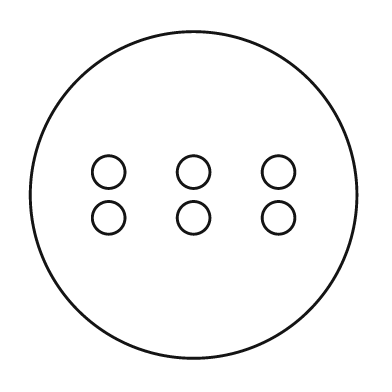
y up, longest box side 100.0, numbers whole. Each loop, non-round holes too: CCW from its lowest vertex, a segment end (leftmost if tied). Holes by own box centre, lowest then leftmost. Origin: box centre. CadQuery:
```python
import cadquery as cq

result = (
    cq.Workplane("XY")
    .moveTo(0.0, 0.0)
    .circle(50.0)
    .moveTo(-26.0, -7.0)
    .circle(5.0)
    .moveTo(0.0, -7.0)
    .circle(5.0)
    .moveTo(26.0, -7.0)
    .circle(5.0)
    .moveTo(-26.0, 7.0)
    .circle(5.0)
    .moveTo(0.0, 7.0)
    .circle(5.0)
    .moveTo(26.0, 7.0)
    .circle(5.0)
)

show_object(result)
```